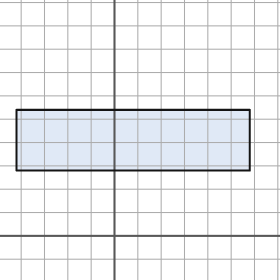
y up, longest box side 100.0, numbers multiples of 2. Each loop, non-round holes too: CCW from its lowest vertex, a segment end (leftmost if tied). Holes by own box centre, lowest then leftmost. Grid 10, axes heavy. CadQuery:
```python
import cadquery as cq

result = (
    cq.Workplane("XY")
    .moveTo(-42.0, 28.0)
    .lineTo(58.0, 28.0)
    .lineTo(58.0, 54.0)
    .lineTo(-42.0, 54.0)
    .close()
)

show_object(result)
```